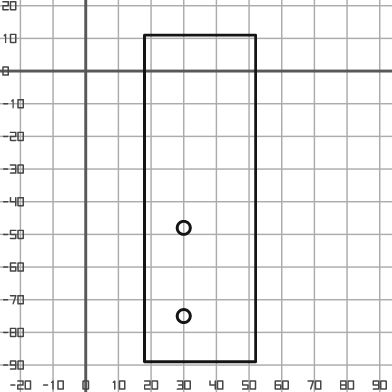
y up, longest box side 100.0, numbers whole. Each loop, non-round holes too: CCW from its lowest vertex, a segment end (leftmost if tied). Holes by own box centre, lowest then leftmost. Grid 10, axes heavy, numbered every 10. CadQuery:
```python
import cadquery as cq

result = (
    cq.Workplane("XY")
    .moveTo(18.0, -89.0)
    .lineTo(52.0, -89.0)
    .lineTo(52.0, 11.0)
    .lineTo(18.0, 11.0)
    .close()
    .moveTo(30.0, -75.0)
    .circle(2.0)
    .moveTo(30.0, -48.0)
    .circle(2.0)
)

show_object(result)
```